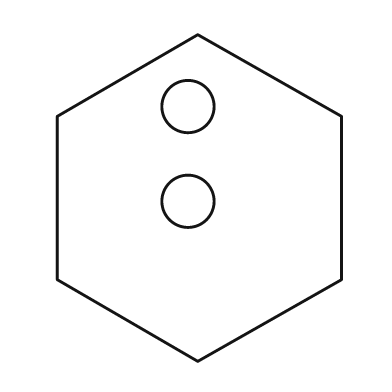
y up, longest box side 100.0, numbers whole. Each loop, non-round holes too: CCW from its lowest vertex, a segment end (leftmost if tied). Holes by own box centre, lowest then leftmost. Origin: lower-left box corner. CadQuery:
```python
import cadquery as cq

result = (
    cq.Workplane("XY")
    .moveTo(43.0, 0.0)
    .lineTo(87.0, 25.0)
    .lineTo(87.0, 75.0)
    .lineTo(43.0, 100.0)
    .lineTo(0.0, 75.0)
    .lineTo(0.0, 25.0)
    .close()
    .moveTo(40.0, 49.0)
    .circle(8.0)
    .moveTo(40.0, 78.0)
    .circle(8.0)
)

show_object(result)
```